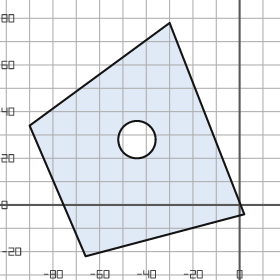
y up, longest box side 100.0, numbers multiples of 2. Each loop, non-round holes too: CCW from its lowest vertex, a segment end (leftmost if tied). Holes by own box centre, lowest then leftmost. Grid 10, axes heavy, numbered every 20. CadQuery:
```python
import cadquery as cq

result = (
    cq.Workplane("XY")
    .moveTo(-66.0, -22.0)
    .lineTo(2.0, -4.0)
    .lineTo(-30.0, 78.0)
    .lineTo(-90.0, 34.0)
    .close()
    .moveTo(-44.0, 28.0)
    .circle(8.0)
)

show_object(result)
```